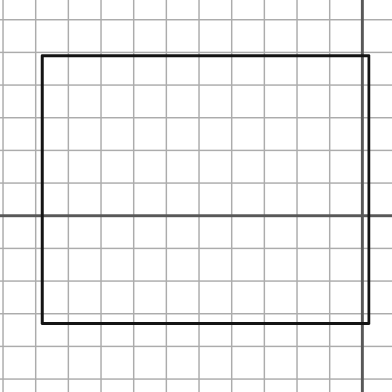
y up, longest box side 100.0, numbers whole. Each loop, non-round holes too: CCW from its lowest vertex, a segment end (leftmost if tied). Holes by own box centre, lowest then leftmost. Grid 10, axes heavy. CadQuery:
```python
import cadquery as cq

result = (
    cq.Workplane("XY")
    .moveTo(-98.0, -33.0)
    .lineTo(2.0, -33.0)
    .lineTo(2.0, 49.0)
    .lineTo(-98.0, 49.0)
    .close()
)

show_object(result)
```